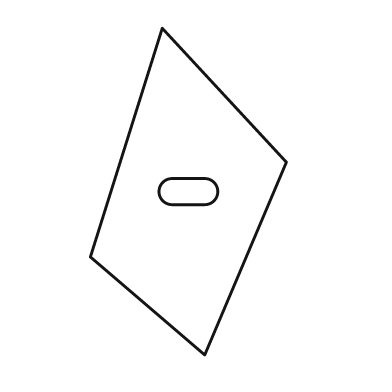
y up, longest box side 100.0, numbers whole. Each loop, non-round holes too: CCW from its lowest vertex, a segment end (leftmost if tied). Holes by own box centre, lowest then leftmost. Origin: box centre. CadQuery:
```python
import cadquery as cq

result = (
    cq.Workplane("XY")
    .moveTo(5.0, -50.0)
    .lineTo(30.0, 9.0)
    .lineTo(-8.0, 50.0)
    .lineTo(-30.0, -20.0)
    .close()
    .moveTo(-5.0, -4.0)
    .lineTo(5.0, -4.0)
    .threePointArc((9.0, 0.0), (5.0, 4.0))
    .lineTo(-5.0, 4.0)
    .threePointArc((-9.0, 0.0), (-5.0, -4.0))
    .close()
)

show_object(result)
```